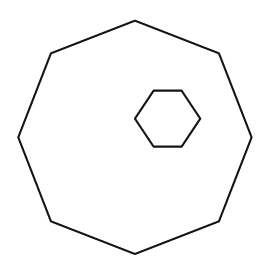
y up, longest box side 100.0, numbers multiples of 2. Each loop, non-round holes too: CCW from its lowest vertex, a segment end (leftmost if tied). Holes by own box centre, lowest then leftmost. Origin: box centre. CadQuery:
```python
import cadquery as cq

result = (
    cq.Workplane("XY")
    .moveTo(0.0, -50.0)
    .lineTo(36.0, -36.0)
    .lineTo(50.0, 0.0)
    .lineTo(36.0, 36.0)
    .lineTo(0.0, 50.0)
    .lineTo(-36.0, 36.0)
    .lineTo(-50.0, 0.0)
    .lineTo(-36.0, -36.0)
    .close()
    .moveTo(8.0, -4.0)
    .lineTo(20.0, -4.0)
    .lineTo(28.0, 8.0)
    .lineTo(20.0, 20.0)
    .lineTo(8.0, 20.0)
    .lineTo(0.0, 8.0)
    .close()
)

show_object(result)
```